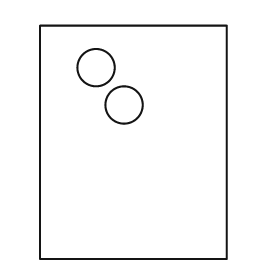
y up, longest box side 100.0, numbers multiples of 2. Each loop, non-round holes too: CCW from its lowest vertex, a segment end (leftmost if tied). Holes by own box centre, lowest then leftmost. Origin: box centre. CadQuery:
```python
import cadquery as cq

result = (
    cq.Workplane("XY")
    .moveTo(-40.0, -50.0)
    .lineTo(40.0, -50.0)
    .lineTo(40.0, 50.0)
    .lineTo(-40.0, 50.0)
    .close()
    .moveTo(-4.0, 16.0)
    .circle(8.0)
    .moveTo(-16.0, 32.0)
    .circle(8.0)
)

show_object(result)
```